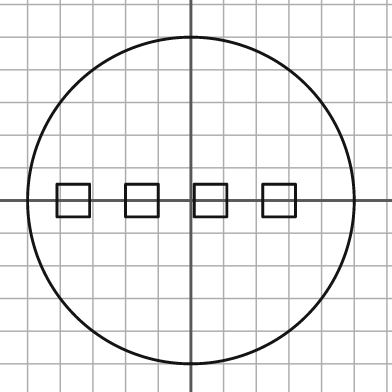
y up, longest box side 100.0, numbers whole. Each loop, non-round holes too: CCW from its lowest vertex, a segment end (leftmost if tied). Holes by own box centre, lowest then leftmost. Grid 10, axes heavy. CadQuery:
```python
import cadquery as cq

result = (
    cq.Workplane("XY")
    .moveTo(0.0, 0.0)
    .circle(50.0)
    .moveTo(-41.0, -5.0)
    .lineTo(-31.0, -5.0)
    .lineTo(-31.0, 5.0)
    .lineTo(-41.0, 5.0)
    .close()
    .moveTo(-20.0, -5.0)
    .lineTo(-10.0, -5.0)
    .lineTo(-10.0, 5.0)
    .lineTo(-20.0, 5.0)
    .close()
    .moveTo(1.0, -5.0)
    .lineTo(11.0, -5.0)
    .lineTo(11.0, 5.0)
    .lineTo(1.0, 5.0)
    .close()
    .moveTo(22.0, -5.0)
    .lineTo(32.0, -5.0)
    .lineTo(32.0, 5.0)
    .lineTo(22.0, 5.0)
    .close()
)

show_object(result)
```